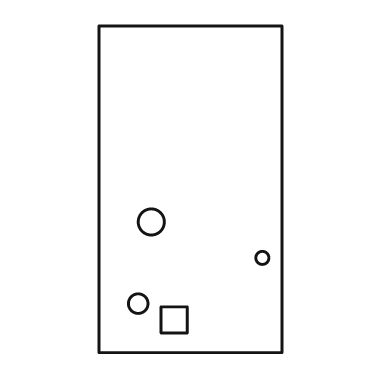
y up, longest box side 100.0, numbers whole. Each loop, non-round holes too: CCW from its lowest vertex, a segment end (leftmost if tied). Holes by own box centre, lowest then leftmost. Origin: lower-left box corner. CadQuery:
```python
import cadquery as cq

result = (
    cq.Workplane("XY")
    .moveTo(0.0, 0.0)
    .lineTo(56.0, 0.0)
    .lineTo(56.0, 100.0)
    .lineTo(0.0, 100.0)
    .close()
    .moveTo(19.0, 6.0)
    .lineTo(27.0, 6.0)
    .lineTo(27.0, 14.0)
    .lineTo(19.0, 14.0)
    .close()
    .moveTo(12.0, 15.0)
    .circle(3.0)
    .moveTo(50.0, 29.0)
    .circle(2.0)
    .moveTo(16.0, 40.0)
    .circle(4.0)
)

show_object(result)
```